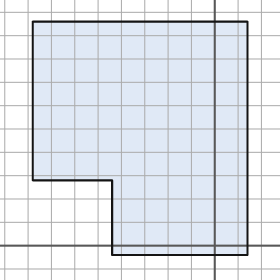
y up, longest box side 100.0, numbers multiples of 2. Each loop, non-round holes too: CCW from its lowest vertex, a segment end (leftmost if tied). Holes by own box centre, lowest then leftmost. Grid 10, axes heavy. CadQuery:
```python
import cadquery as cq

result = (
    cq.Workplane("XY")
    .moveTo(-44.0, -4.0)
    .lineTo(14.0, -4.0)
    .lineTo(14.0, 96.0)
    .lineTo(-78.0, 96.0)
    .lineTo(-78.0, 28.0)
    .lineTo(-44.0, 28.0)
    .close()
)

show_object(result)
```